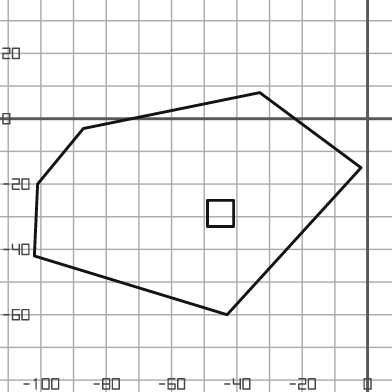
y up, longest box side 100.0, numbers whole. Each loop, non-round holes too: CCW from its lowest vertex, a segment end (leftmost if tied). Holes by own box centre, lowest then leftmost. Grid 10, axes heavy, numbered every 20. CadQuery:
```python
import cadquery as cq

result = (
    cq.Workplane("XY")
    .moveTo(-43.0, -60.0)
    .lineTo(-2.0, -15.0)
    .lineTo(-33.0, 8.0)
    .lineTo(-87.0, -3.0)
    .lineTo(-101.0, -20.0)
    .lineTo(-102.0, -42.0)
    .close()
    .moveTo(-49.0, -33.0)
    .lineTo(-41.0, -33.0)
    .lineTo(-41.0, -25.0)
    .lineTo(-49.0, -25.0)
    .close()
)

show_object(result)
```